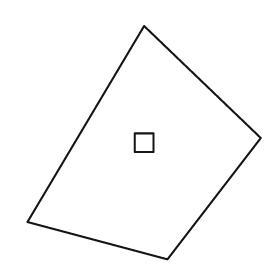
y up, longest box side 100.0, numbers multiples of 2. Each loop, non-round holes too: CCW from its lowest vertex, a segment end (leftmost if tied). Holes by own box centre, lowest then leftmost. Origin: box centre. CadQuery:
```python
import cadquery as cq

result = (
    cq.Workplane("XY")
    .moveTo(10.0, -50.0)
    .lineTo(50.0, 2.0)
    .lineTo(0.0, 50.0)
    .lineTo(-50.0, -34.0)
    .close()
    .moveTo(-4.0, -4.0)
    .lineTo(4.0, -4.0)
    .lineTo(4.0, 4.0)
    .lineTo(-4.0, 4.0)
    .close()
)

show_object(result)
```